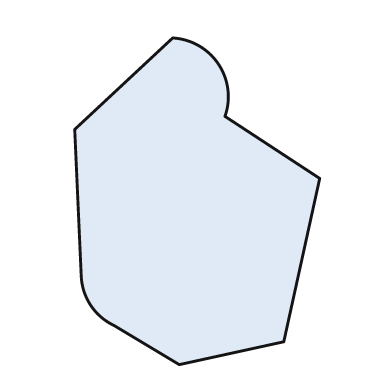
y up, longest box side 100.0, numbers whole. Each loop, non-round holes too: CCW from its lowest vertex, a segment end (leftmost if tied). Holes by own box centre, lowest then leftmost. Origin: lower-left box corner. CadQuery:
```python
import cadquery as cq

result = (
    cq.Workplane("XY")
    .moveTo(32.0, 0.0)
    .lineTo(64.0, 7.0)
    .lineTo(75.0, 57.0)
    .lineTo(46.0, 76.0)
    .threePointArc((44.0, 92.0), (30.0, 100.0))
    .lineTo(0.0, 72.0)
    .lineTo(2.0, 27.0)
    .threePointArc((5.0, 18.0), (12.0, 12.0))
    .close()
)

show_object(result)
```